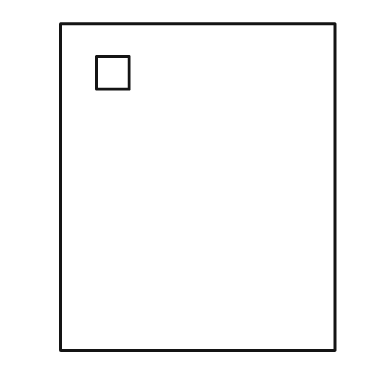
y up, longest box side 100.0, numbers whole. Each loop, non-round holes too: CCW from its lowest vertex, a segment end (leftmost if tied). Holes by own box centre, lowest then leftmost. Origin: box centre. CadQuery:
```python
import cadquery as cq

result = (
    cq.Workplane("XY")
    .moveTo(-42.0, -50.0)
    .lineTo(42.0, -50.0)
    .lineTo(42.0, 50.0)
    .lineTo(-42.0, 50.0)
    .close()
    .moveTo(-31.0, 30.0)
    .lineTo(-21.0, 30.0)
    .lineTo(-21.0, 40.0)
    .lineTo(-31.0, 40.0)
    .close()
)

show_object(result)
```